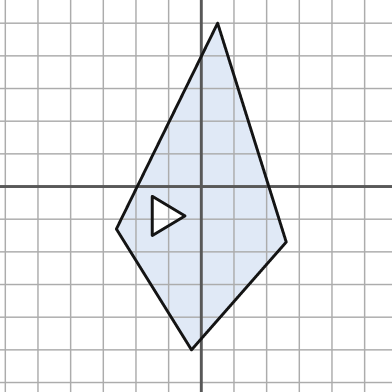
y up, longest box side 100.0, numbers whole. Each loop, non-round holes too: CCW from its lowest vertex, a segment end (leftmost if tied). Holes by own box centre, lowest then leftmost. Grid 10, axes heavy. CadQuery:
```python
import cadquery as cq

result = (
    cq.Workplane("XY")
    .moveTo(-3.0, -50.0)
    .lineTo(26.0, -17.0)
    .lineTo(5.0, 50.0)
    .lineTo(-26.0, -13.0)
    .close()
    .moveTo(-15.0, -15.0)
    .lineTo(-5.0, -9.0)
    .lineTo(-15.0, -3.0)
    .close()
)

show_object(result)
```